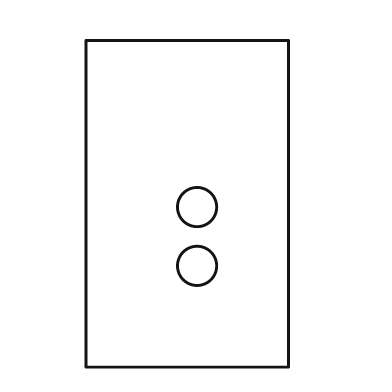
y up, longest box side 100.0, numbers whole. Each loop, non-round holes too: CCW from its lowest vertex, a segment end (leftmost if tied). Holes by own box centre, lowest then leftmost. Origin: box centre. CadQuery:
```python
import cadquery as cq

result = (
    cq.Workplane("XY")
    .moveTo(-31.0, -50.0)
    .lineTo(31.0, -50.0)
    .lineTo(31.0, 50.0)
    .lineTo(-31.0, 50.0)
    .close()
    .moveTo(3.0, -19.0)
    .circle(6.0)
    .moveTo(3.0, -1.0)
    .circle(6.0)
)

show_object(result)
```